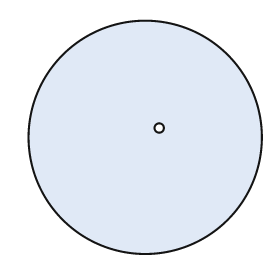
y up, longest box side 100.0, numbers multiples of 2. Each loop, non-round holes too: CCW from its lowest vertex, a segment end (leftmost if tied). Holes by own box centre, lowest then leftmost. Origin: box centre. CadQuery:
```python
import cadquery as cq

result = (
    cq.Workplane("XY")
    .moveTo(0.0, 0.0)
    .circle(50.0)
    .moveTo(6.0, 4.0)
    .circle(2.0)
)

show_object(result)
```